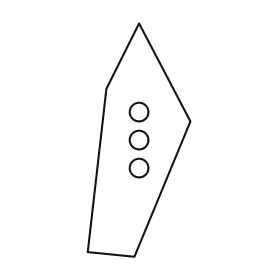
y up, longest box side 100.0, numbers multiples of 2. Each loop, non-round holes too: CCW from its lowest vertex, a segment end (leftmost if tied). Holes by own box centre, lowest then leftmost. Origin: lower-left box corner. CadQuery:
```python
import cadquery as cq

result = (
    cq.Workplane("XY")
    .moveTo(20.0, 0.0)
    .lineTo(44.0, 58.0)
    .lineTo(22.0, 100.0)
    .lineTo(8.0, 72.0)
    .lineTo(0.0, 2.0)
    .close()
    .moveTo(22.0, 38.0)
    .circle(4.0)
    .moveTo(22.0, 50.0)
    .circle(4.0)
    .moveTo(22.0, 62.0)
    .circle(4.0)
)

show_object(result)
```